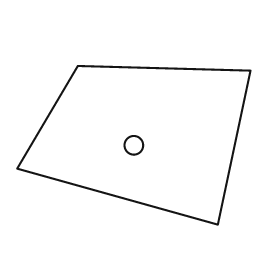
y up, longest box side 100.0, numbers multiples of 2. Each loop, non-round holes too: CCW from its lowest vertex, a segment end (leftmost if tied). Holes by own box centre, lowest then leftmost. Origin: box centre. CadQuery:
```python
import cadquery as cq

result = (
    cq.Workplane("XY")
    .moveTo(36.0, -34.0)
    .lineTo(50.0, 32.0)
    .lineTo(-24.0, 34.0)
    .lineTo(-50.0, -10.0)
    .close()
    .moveTo(0.0, 0.0)
    .circle(4.0)
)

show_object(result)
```